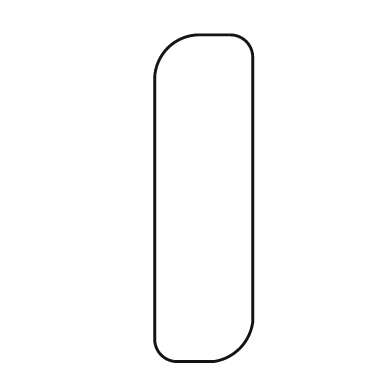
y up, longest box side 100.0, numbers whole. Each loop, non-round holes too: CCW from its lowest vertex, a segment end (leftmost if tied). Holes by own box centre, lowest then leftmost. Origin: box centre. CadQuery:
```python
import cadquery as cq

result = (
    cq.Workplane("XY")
    .moveTo(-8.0, -50.0)
    .lineTo(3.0, -50.0)
    .threePointArc((11.0, -46.0), (15.0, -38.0))
    .lineTo(15.0, 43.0)
    .threePointArc((13.0, 48.0), (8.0, 50.0))
    .lineTo(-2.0, 50.0)
    .threePointArc((-11.0, 46.0), (-15.0, 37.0))
    .lineTo(-15.0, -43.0)
    .threePointArc((-13.0, -48.0), (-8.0, -50.0))
    .close()
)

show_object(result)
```